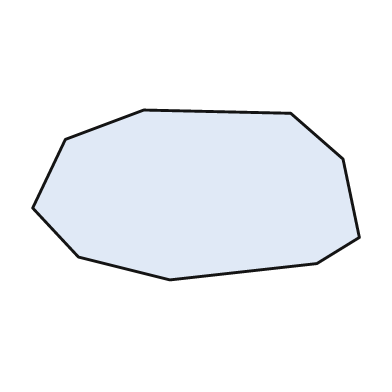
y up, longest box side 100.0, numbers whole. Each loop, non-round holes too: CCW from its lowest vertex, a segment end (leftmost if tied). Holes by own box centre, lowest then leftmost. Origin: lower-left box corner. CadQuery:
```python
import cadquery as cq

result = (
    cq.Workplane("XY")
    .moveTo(42.0, 0.0)
    .lineTo(87.0, 5.0)
    .lineTo(100.0, 13.0)
    .lineTo(95.0, 37.0)
    .lineTo(79.0, 51.0)
    .lineTo(34.0, 52.0)
    .lineTo(10.0, 43.0)
    .lineTo(0.0, 22.0)
    .lineTo(14.0, 7.0)
    .close()
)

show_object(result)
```